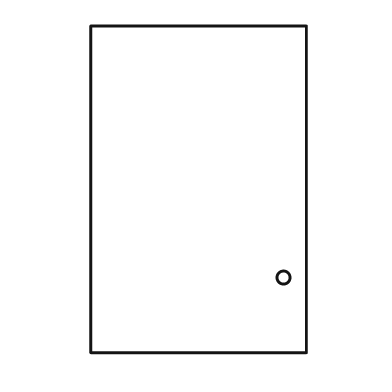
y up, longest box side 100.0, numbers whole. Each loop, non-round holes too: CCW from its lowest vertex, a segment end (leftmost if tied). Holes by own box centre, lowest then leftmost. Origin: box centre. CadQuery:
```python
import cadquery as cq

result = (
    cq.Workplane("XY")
    .moveTo(-33.0, -50.0)
    .lineTo(33.0, -50.0)
    .lineTo(33.0, 50.0)
    .lineTo(-33.0, 50.0)
    .close()
    .moveTo(26.0, -27.0)
    .circle(2.0)
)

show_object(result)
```